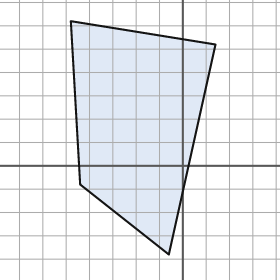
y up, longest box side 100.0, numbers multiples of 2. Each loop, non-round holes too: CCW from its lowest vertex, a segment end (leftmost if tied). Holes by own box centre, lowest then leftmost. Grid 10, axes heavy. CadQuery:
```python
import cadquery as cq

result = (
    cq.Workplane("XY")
    .moveTo(-6.0, -38.0)
    .lineTo(14.0, 52.0)
    .lineTo(-48.0, 62.0)
    .lineTo(-44.0, -8.0)
    .close()
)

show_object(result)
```